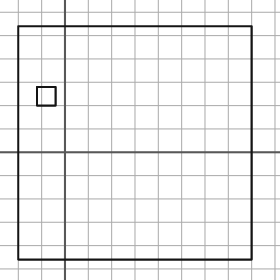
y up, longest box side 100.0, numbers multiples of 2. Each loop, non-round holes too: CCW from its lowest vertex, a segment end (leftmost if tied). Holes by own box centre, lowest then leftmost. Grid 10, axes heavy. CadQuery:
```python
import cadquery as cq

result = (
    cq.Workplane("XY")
    .moveTo(-20.0, -46.0)
    .lineTo(80.0, -46.0)
    .lineTo(80.0, 54.0)
    .lineTo(-20.0, 54.0)
    .close()
    .moveTo(-12.0, 20.0)
    .lineTo(-4.0, 20.0)
    .lineTo(-4.0, 28.0)
    .lineTo(-12.0, 28.0)
    .close()
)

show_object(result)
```